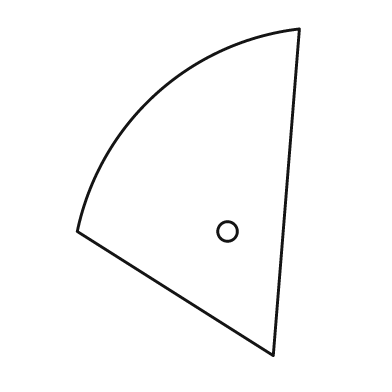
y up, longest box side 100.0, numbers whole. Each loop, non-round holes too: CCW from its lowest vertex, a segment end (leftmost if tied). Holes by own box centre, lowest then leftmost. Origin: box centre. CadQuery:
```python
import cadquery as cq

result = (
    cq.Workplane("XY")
    .moveTo(26.0, -50.0)
    .lineTo(34.0, 50.0)
    .threePointArc((-10.0, 30.0), (-34.0, -12.0))
    .close()
    .moveTo(12.0, -12.0)
    .circle(3.0)
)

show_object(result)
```